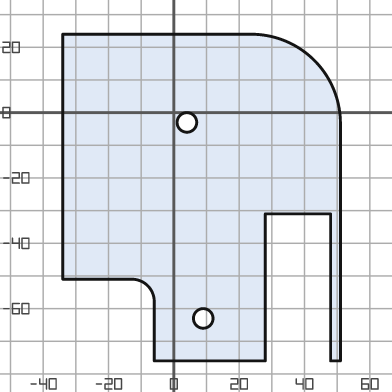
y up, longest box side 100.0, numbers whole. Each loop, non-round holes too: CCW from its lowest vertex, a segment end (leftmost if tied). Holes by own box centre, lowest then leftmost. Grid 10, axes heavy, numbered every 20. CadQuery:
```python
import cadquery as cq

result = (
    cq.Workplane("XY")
    .moveTo(-6.0, -76.0)
    .lineTo(28.0, -76.0)
    .lineTo(28.0, -31.0)
    .lineTo(48.0, -31.0)
    .lineTo(48.0, -76.0)
    .lineTo(51.0, -76.0)
    .lineTo(51.0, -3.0)
    .threePointArc((43.0, 16.0), (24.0, 24.0))
    .lineTo(-34.0, 24.0)
    .lineTo(-34.0, -51.0)
    .lineTo(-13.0, -51.0)
    .threePointArc((-8.0, -53.0), (-6.0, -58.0))
    .close()
    .moveTo(9.0, -63.0)
    .circle(3.0)
    .moveTo(4.0, -3.0)
    .circle(3.0)
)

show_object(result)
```